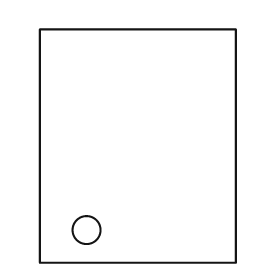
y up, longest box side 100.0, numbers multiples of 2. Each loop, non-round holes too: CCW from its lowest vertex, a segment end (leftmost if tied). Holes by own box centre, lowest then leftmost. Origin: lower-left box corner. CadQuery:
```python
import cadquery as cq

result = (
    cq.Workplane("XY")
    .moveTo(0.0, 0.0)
    .lineTo(84.0, 0.0)
    .lineTo(84.0, 100.0)
    .lineTo(0.0, 100.0)
    .close()
    .moveTo(20.0, 14.0)
    .circle(6.0)
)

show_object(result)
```